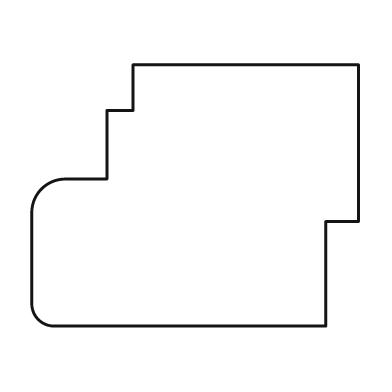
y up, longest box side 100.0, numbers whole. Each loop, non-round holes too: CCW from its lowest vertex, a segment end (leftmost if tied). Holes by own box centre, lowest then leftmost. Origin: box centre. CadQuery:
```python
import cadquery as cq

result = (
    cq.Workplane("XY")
    .moveTo(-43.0, -40.0)
    .lineTo(40.0, -40.0)
    .lineTo(40.0, -8.0)
    .lineTo(50.0, -8.0)
    .lineTo(50.0, 40.0)
    .lineTo(-19.0, 40.0)
    .lineTo(-19.0, 26.0)
    .lineTo(-27.0, 26.0)
    .lineTo(-27.0, 5.0)
    .lineTo(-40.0, 5.0)
    .threePointArc((-47.0, 2.0), (-50.0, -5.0))
    .lineTo(-50.0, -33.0)
    .threePointArc((-48.0, -38.0), (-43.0, -40.0))
    .close()
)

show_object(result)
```